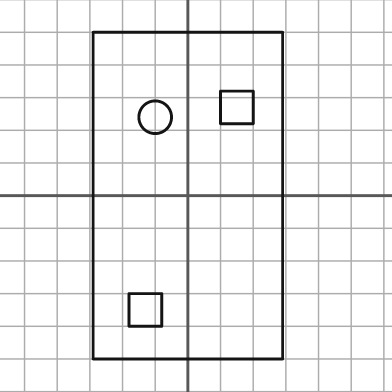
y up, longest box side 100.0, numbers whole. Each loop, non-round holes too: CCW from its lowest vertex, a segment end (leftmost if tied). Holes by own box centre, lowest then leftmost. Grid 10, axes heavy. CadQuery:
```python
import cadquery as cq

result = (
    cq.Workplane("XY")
    .moveTo(-29.0, -50.0)
    .lineTo(29.0, -50.0)
    .lineTo(29.0, 50.0)
    .lineTo(-29.0, 50.0)
    .close()
    .moveTo(-18.0, -40.0)
    .lineTo(-8.0, -40.0)
    .lineTo(-8.0, -30.0)
    .lineTo(-18.0, -30.0)
    .close()
    .moveTo(-10.0, 24.0)
    .circle(5.0)
    .moveTo(10.0, 22.0)
    .lineTo(20.0, 22.0)
    .lineTo(20.0, 32.0)
    .lineTo(10.0, 32.0)
    .close()
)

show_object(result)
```